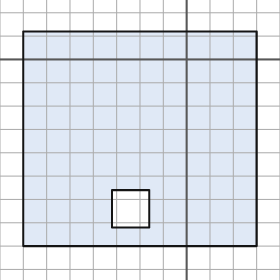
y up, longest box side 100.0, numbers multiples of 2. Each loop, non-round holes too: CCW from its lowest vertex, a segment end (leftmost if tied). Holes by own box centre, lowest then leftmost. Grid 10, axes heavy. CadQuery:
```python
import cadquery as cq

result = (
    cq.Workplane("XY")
    .moveTo(-70.0, -80.0)
    .lineTo(30.0, -80.0)
    .lineTo(30.0, 12.0)
    .lineTo(-70.0, 12.0)
    .close()
    .moveTo(-32.0, -72.0)
    .lineTo(-16.0, -72.0)
    .lineTo(-16.0, -56.0)
    .lineTo(-32.0, -56.0)
    .close()
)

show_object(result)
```